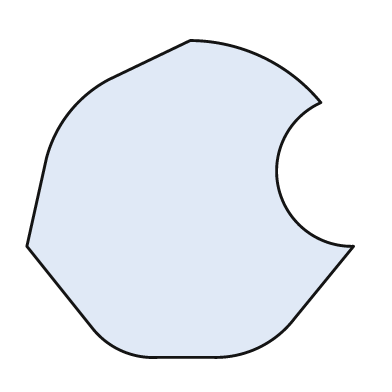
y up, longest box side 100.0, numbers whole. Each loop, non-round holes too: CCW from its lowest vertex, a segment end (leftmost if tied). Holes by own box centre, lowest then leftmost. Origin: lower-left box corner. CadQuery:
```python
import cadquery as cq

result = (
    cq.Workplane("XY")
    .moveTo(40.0, 0.0)
    .lineTo(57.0, 0.0)
    .threePointArc((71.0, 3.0), (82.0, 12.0))
    .lineTo(100.0, 34.0)
    .threePointArc((77.0, 52.0), (90.0, 78.0))
    .threePointArc((72.0, 92.0), (50.0, 97.0))
    .lineTo(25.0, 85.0)
    .threePointArc((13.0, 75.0), (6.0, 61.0))
    .lineTo(0.0, 34.0)
    .lineTo(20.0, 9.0)
    .threePointArc((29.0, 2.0), (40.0, 0.0))
    .close()
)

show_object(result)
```